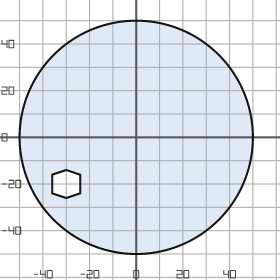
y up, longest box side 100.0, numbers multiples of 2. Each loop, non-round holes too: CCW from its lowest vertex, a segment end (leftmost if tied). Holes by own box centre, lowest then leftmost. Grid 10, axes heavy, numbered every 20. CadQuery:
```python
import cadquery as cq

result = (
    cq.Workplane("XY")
    .moveTo(0.0, 0.0)
    .circle(50.0)
    .moveTo(-30.0, -26.0)
    .lineTo(-24.0, -24.0)
    .lineTo(-24.0, -16.0)
    .lineTo(-30.0, -14.0)
    .lineTo(-36.0, -16.0)
    .lineTo(-36.0, -24.0)
    .close()
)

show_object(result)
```